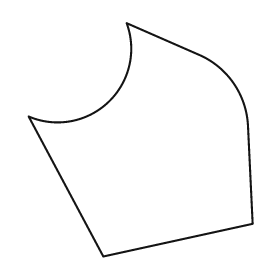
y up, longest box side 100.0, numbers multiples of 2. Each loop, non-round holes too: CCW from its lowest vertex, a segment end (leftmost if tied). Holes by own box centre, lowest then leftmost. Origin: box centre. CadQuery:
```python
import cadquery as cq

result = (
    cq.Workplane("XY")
    .moveTo(-16.0, -50.0)
    .lineTo(48.0, -36.0)
    .lineTo(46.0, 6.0)
    .threePointArc((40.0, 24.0), (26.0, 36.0))
    .lineTo(-6.0, 50.0)
    .threePointArc((-14.0, 16.0), (-48.0, 10.0))
    .close()
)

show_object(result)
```